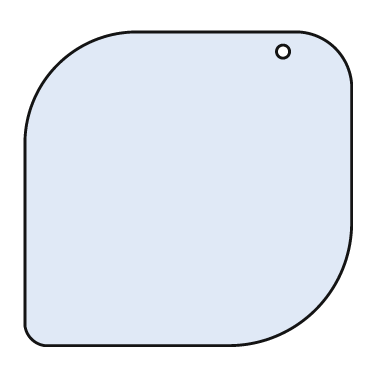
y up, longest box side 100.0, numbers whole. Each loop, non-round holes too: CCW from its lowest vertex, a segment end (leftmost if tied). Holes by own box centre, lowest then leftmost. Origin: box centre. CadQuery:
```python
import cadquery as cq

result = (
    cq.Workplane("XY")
    .moveTo(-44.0, -48.0)
    .lineTo(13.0, -48.0)
    .threePointArc((39.0, -37.0), (50.0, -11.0))
    .lineTo(50.0, 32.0)
    .threePointArc((45.0, 43.0), (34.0, 48.0))
    .lineTo(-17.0, 48.0)
    .threePointArc((-40.0, 38.0), (-50.0, 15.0))
    .lineTo(-50.0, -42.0)
    .threePointArc((-48.0, -46.0), (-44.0, -48.0))
    .close()
    .moveTo(29.0, 42.0)
    .circle(2.0)
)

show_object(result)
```